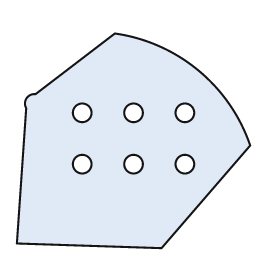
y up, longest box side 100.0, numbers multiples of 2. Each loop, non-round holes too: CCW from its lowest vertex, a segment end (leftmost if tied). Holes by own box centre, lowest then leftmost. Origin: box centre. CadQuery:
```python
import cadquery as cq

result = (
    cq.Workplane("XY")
    .moveTo(12.0, -46.0)
    .lineTo(50.0, -2.0)
    .threePointArc((28.0, 30.0), (-8.0, 46.0))
    .lineTo(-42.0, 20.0)
    .threePointArc((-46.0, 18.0), (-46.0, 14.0))
    .lineTo(-50.0, -44.0)
    .close()
    .moveTo(-22.0, -10.0)
    .circle(4.0)
    .moveTo(0.0, -10.0)
    .circle(4.0)
    .moveTo(22.0, -10.0)
    .circle(4.0)
    .moveTo(-22.0, 12.0)
    .circle(4.0)
    .moveTo(0.0, 12.0)
    .circle(4.0)
    .moveTo(22.0, 12.0)
    .circle(4.0)
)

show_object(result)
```